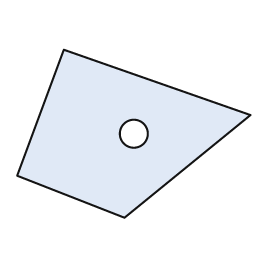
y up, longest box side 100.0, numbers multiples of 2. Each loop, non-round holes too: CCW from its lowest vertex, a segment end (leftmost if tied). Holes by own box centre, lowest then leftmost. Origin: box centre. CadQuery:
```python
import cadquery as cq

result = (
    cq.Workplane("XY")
    .moveTo(-4.0, -36.0)
    .lineTo(50.0, 8.0)
    .lineTo(-30.0, 36.0)
    .lineTo(-50.0, -18.0)
    .close()
    .moveTo(0.0, 0.0)
    .circle(6.0)
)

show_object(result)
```